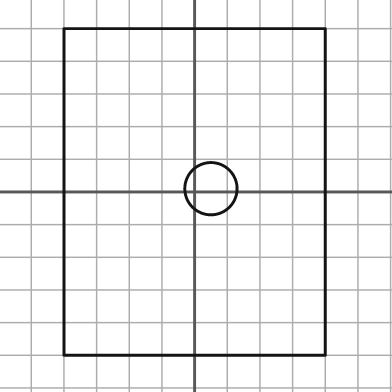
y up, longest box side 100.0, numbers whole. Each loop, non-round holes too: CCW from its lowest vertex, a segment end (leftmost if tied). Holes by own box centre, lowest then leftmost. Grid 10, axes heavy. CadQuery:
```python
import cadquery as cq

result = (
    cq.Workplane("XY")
    .moveTo(-40.0, -50.0)
    .lineTo(40.0, -50.0)
    .lineTo(40.0, 50.0)
    .lineTo(-40.0, 50.0)
    .close()
    .moveTo(5.0, 1.0)
    .circle(8.0)
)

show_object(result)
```